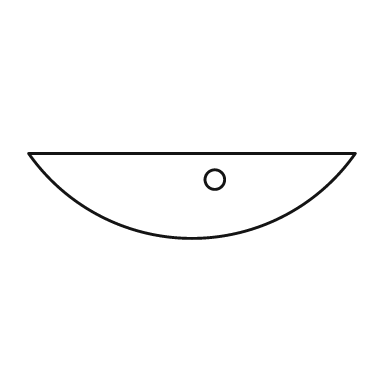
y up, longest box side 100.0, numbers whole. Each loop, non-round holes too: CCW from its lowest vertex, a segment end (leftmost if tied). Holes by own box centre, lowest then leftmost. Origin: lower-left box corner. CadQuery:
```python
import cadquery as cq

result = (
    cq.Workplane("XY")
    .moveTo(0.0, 26.0)
    .threePointArc((50.0, 0.0), (100.0, 26.0))
    .close()
    .moveTo(57.0, 18.0)
    .circle(3.0)
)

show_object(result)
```